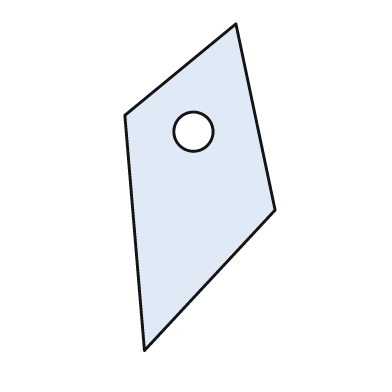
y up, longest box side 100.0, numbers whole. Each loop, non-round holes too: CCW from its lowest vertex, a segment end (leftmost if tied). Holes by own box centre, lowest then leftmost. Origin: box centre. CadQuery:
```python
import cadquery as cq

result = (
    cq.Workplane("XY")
    .moveTo(-17.0, -50.0)
    .lineTo(23.0, -7.0)
    .lineTo(11.0, 50.0)
    .lineTo(-23.0, 22.0)
    .close()
    .moveTo(-2.0, 17.0)
    .circle(6.0)
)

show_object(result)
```